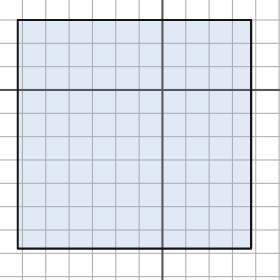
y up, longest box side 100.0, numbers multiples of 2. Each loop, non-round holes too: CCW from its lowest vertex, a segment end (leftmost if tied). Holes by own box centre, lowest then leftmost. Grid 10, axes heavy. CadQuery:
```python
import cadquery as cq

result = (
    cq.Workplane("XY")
    .moveTo(-62.0, -68.0)
    .lineTo(38.0, -68.0)
    .lineTo(38.0, 30.0)
    .lineTo(-62.0, 30.0)
    .close()
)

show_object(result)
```